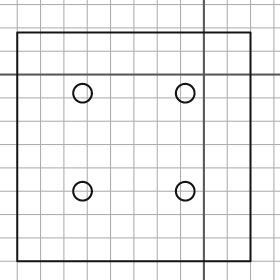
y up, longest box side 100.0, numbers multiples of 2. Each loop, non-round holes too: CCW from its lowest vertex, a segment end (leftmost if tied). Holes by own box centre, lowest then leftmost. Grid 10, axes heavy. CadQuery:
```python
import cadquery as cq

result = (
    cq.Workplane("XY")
    .moveTo(-80.0, -80.0)
    .lineTo(20.0, -80.0)
    .lineTo(20.0, 18.0)
    .lineTo(-80.0, 18.0)
    .close()
    .moveTo(-52.0, -50.0)
    .circle(4.0)
    .moveTo(-8.0, -50.0)
    .circle(4.0)
    .moveTo(-52.0, -8.0)
    .circle(4.0)
    .moveTo(-8.0, -8.0)
    .circle(4.0)
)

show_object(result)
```